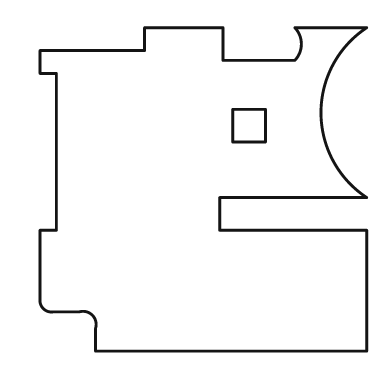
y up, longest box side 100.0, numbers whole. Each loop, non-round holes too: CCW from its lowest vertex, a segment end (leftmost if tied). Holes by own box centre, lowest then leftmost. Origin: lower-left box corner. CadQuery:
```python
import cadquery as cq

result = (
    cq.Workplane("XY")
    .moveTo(17.0, 0.0)
    .lineTo(100.0, 0.0)
    .lineTo(100.0, 37.0)
    .lineTo(55.0, 37.0)
    .lineTo(55.0, 47.0)
    .lineTo(100.0, 47.0)
    .threePointArc((86.0, 73.0), (100.0, 99.0))
    .lineTo(78.0, 99.0)
    .threePointArc((80.0, 94.0), (78.0, 89.0))
    .lineTo(56.0, 89.0)
    .lineTo(56.0, 99.0)
    .lineTo(32.0, 99.0)
    .lineTo(32.0, 92.0)
    .lineTo(0.0, 92.0)
    .lineTo(0.0, 85.0)
    .lineTo(5.0, 85.0)
    .lineTo(5.0, 37.0)
    .lineTo(0.0, 37.0)
    .lineTo(0.0, 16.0)
    .threePointArc((1.0, 13.0), (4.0, 12.0))
    .lineTo(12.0, 12.0)
    .threePointArc((16.0, 11.0), (17.0, 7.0))
    .close()
    .moveTo(59.0, 64.0)
    .lineTo(69.0, 64.0)
    .lineTo(69.0, 74.0)
    .lineTo(59.0, 74.0)
    .close()
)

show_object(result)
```